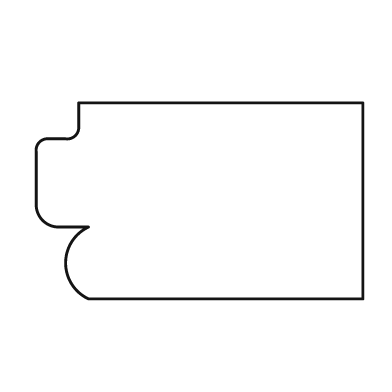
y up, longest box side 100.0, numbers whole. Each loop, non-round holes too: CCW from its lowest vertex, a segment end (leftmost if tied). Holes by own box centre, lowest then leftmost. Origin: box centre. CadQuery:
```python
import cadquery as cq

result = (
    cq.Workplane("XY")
    .moveTo(-34.0, -30.0)
    .lineTo(50.0, -30.0)
    .lineTo(50.0, 30.0)
    .lineTo(-37.0, 30.0)
    .lineTo(-37.0, 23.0)
    .threePointArc((-38.0, 20.0), (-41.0, 19.0))
    .lineTo(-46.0, 19.0)
    .threePointArc((-49.0, 18.0), (-50.0, 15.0))
    .lineTo(-50.0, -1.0)
    .threePointArc((-48.0, -6.0), (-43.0, -8.0))
    .lineTo(-34.0, -8.0)
    .threePointArc((-41.0, -19.0), (-34.0, -30.0))
    .close()
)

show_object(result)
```